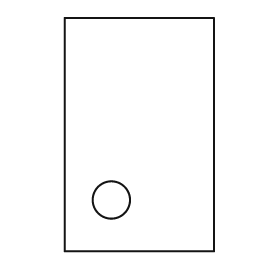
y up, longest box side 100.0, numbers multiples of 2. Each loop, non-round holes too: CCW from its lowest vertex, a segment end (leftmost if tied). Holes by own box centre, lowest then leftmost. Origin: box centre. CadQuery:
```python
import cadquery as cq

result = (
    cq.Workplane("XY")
    .moveTo(-32.0, -50.0)
    .lineTo(32.0, -50.0)
    .lineTo(32.0, 50.0)
    .lineTo(-32.0, 50.0)
    .close()
    .moveTo(-12.0, -28.0)
    .circle(8.0)
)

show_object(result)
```